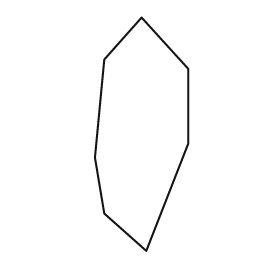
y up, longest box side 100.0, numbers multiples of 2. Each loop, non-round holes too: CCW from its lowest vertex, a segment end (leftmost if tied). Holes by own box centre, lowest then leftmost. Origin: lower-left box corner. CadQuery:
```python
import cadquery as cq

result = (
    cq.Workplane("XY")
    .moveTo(22.0, 0.0)
    .lineTo(40.0, 46.0)
    .lineTo(40.0, 78.0)
    .lineTo(20.0, 100.0)
    .lineTo(4.0, 82.0)
    .lineTo(0.0, 40.0)
    .lineTo(4.0, 16.0)
    .close()
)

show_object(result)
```